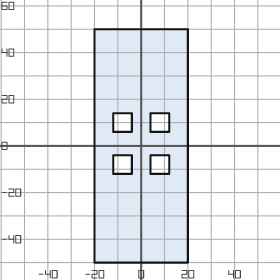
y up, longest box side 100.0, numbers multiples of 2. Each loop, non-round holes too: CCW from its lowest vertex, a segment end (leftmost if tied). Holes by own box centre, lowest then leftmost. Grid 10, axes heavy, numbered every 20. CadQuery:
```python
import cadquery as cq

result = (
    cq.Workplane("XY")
    .moveTo(-20.0, -50.0)
    .lineTo(20.0, -50.0)
    .lineTo(20.0, 50.0)
    .lineTo(-20.0, 50.0)
    .close()
    .moveTo(-12.0, -12.0)
    .lineTo(-4.0, -12.0)
    .lineTo(-4.0, -4.0)
    .lineTo(-12.0, -4.0)
    .close()
    .moveTo(4.0, -12.0)
    .lineTo(12.0, -12.0)
    .lineTo(12.0, -4.0)
    .lineTo(4.0, -4.0)
    .close()
    .moveTo(-12.0, 6.0)
    .lineTo(-4.0, 6.0)
    .lineTo(-4.0, 14.0)
    .lineTo(-12.0, 14.0)
    .close()
    .moveTo(4.0, 6.0)
    .lineTo(12.0, 6.0)
    .lineTo(12.0, 14.0)
    .lineTo(4.0, 14.0)
    .close()
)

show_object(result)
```